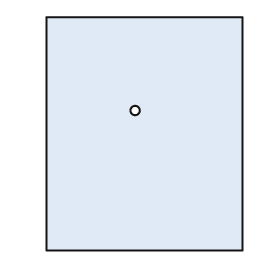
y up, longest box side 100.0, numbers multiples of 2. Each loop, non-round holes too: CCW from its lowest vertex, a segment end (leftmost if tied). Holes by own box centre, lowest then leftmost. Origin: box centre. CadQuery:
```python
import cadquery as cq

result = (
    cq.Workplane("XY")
    .moveTo(-42.0, -50.0)
    .lineTo(42.0, -50.0)
    .lineTo(42.0, 50.0)
    .lineTo(-42.0, 50.0)
    .close()
    .moveTo(-4.0, 10.0)
    .circle(2.0)
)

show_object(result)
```